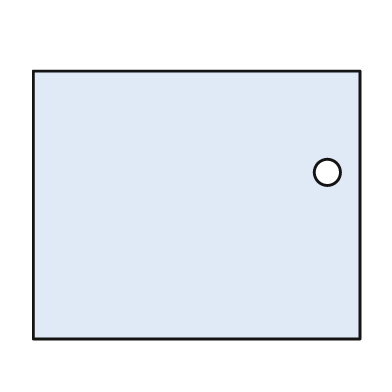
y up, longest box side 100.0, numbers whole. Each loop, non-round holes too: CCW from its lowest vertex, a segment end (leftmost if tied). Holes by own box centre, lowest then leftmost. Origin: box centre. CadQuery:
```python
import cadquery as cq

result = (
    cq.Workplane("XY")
    .moveTo(-50.0, -41.0)
    .lineTo(50.0, -41.0)
    .lineTo(50.0, 41.0)
    .lineTo(-50.0, 41.0)
    .close()
    .moveTo(40.0, 10.0)
    .circle(4.0)
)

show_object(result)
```